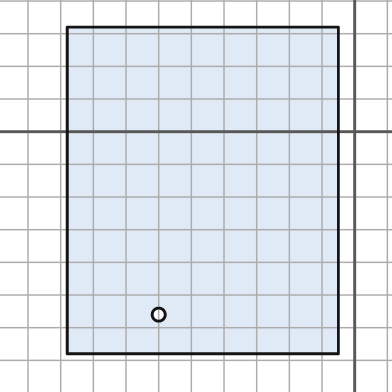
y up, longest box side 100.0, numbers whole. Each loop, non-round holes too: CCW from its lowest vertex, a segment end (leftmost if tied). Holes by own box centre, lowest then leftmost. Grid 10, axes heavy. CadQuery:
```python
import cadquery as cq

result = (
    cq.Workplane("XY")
    .moveTo(-88.0, -68.0)
    .lineTo(-5.0, -68.0)
    .lineTo(-5.0, 32.0)
    .lineTo(-88.0, 32.0)
    .close()
    .moveTo(-60.0, -56.0)
    .circle(2.0)
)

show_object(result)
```